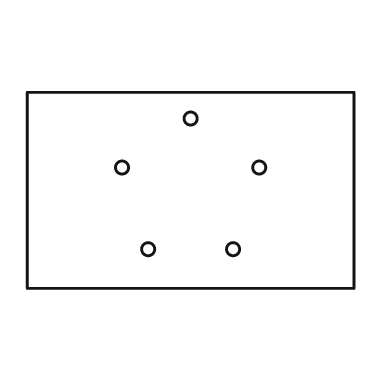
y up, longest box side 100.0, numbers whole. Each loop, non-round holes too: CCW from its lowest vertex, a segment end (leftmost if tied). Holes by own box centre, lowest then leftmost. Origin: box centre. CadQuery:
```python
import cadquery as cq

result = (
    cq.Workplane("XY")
    .moveTo(-50.0, -30.0)
    .lineTo(50.0, -30.0)
    .lineTo(50.0, 30.0)
    .lineTo(-50.0, 30.0)
    .close()
    .moveTo(-13.0, -18.0)
    .circle(2.0)
    .moveTo(13.0, -18.0)
    .circle(2.0)
    .moveTo(-21.0, 7.0)
    .circle(2.0)
    .moveTo(21.0, 7.0)
    .circle(2.0)
    .moveTo(0.0, 22.0)
    .circle(2.0)
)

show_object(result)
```